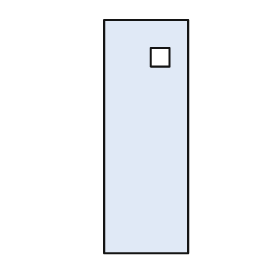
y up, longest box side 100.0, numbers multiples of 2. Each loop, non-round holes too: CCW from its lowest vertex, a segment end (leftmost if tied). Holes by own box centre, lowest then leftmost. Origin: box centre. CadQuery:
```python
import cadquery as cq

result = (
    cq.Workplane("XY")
    .moveTo(-18.0, -50.0)
    .lineTo(18.0, -50.0)
    .lineTo(18.0, 50.0)
    .lineTo(-18.0, 50.0)
    .close()
    .moveTo(2.0, 30.0)
    .lineTo(10.0, 30.0)
    .lineTo(10.0, 38.0)
    .lineTo(2.0, 38.0)
    .close()
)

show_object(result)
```